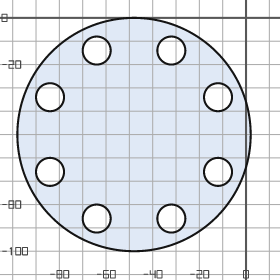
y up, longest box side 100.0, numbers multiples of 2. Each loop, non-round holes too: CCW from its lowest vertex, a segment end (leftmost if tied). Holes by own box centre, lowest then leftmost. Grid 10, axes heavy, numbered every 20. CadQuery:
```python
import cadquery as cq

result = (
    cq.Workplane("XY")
    .moveTo(-48.0, -50.0)
    .circle(50.0)
    .moveTo(-64.0, -86.0)
    .circle(6.0)
    .moveTo(-32.0, -86.0)
    .circle(6.0)
    .moveTo(-84.0, -66.0)
    .circle(6.0)
    .moveTo(-12.0, -66.0)
    .circle(6.0)
    .moveTo(-84.0, -34.0)
    .circle(6.0)
    .moveTo(-12.0, -34.0)
    .circle(6.0)
    .moveTo(-64.0, -14.0)
    .circle(6.0)
    .moveTo(-32.0, -14.0)
    .circle(6.0)
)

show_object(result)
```